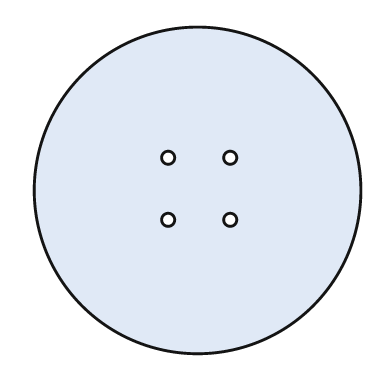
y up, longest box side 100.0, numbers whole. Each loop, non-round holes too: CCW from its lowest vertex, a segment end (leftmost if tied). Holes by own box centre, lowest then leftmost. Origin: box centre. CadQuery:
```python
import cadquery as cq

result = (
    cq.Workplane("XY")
    .moveTo(0.0, 0.0)
    .circle(50.0)
    .moveTo(-9.0, -9.0)
    .circle(2.0)
    .moveTo(10.0, -9.0)
    .circle(2.0)
    .moveTo(-9.0, 10.0)
    .circle(2.0)
    .moveTo(10.0, 10.0)
    .circle(2.0)
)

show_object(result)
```